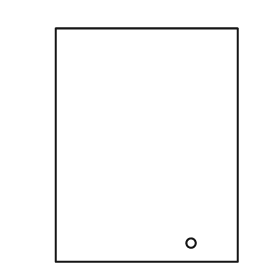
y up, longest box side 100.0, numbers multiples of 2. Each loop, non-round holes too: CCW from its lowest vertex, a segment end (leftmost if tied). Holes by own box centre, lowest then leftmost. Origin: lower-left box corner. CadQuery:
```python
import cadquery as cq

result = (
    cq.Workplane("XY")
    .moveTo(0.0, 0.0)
    .lineTo(78.0, 0.0)
    .lineTo(78.0, 100.0)
    .lineTo(0.0, 100.0)
    .close()
    .moveTo(58.0, 8.0)
    .circle(2.0)
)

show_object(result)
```